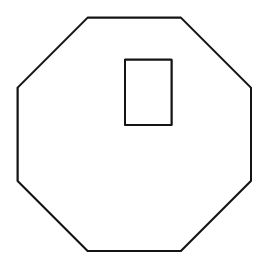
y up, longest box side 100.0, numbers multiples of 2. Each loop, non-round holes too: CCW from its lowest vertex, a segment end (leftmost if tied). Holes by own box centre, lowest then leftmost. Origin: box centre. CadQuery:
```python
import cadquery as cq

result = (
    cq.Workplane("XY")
    .moveTo(-20.0, -50.0)
    .lineTo(20.0, -50.0)
    .lineTo(50.0, -20.0)
    .lineTo(50.0, 20.0)
    .lineTo(20.0, 50.0)
    .lineTo(-20.0, 50.0)
    .lineTo(-50.0, 20.0)
    .lineTo(-50.0, -20.0)
    .close()
    .moveTo(-4.0, 4.0)
    .lineTo(16.0, 4.0)
    .lineTo(16.0, 32.0)
    .lineTo(-4.0, 32.0)
    .close()
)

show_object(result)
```